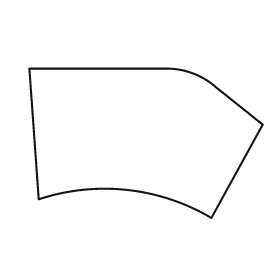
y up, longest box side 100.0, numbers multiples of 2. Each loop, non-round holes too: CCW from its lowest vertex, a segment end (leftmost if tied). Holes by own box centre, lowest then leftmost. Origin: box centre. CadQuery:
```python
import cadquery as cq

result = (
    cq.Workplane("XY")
    .moveTo(28.0, -32.0)
    .lineTo(50.0, 8.0)
    .lineTo(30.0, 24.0)
    .threePointArc((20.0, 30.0), (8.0, 32.0))
    .lineTo(-50.0, 32.0)
    .lineTo(-46.0, -24.0)
    .threePointArc((-8.0, -20.0), (28.0, -32.0))
    .close()
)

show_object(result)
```